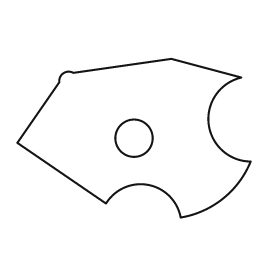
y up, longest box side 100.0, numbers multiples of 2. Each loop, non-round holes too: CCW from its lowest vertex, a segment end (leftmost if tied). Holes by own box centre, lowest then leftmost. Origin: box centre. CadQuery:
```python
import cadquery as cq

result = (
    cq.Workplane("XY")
    .moveTo(20.0, -34.0)
    .threePointArc((38.0, -26.0), (50.0, -10.0))
    .threePointArc((32.0, 6.0), (46.0, 26.0))
    .lineTo(16.0, 34.0)
    .lineTo(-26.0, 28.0)
    .threePointArc((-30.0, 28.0), (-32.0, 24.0))
    .lineTo(-50.0, -2.0)
    .lineTo(-12.0, -28.0)
    .threePointArc((6.0, -20.0), (20.0, -34.0))
    .close()
    .moveTo(0.0, 0.0)
    .circle(8.0)
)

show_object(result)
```